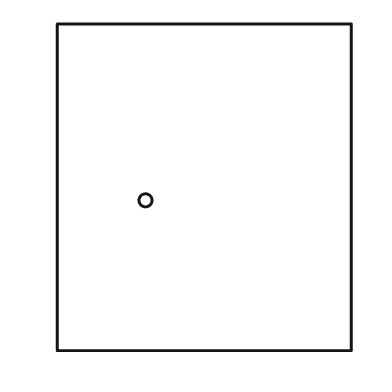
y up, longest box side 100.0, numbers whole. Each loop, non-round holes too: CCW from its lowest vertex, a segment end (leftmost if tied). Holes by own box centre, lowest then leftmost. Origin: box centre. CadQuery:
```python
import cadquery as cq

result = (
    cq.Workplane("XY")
    .moveTo(-45.0, -50.0)
    .lineTo(45.0, -50.0)
    .lineTo(45.0, 50.0)
    .lineTo(-45.0, 50.0)
    .close()
    .moveTo(-18.0, -4.0)
    .circle(2.0)
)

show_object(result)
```